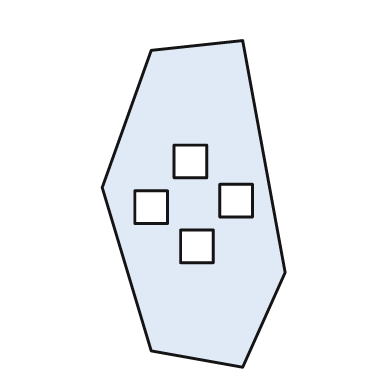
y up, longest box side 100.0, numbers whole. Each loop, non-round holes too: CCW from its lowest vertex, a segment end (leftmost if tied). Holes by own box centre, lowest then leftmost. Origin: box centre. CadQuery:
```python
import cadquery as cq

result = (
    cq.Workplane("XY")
    .moveTo(15.0, -50.0)
    .lineTo(28.0, -21.0)
    .lineTo(15.0, 50.0)
    .lineTo(-13.0, 47.0)
    .lineTo(-28.0, 5.0)
    .lineTo(-13.0, -45.0)
    .close()
    .moveTo(-4.0, -18.0)
    .lineTo(6.0, -18.0)
    .lineTo(6.0, -8.0)
    .lineTo(-4.0, -8.0)
    .close()
    .moveTo(-18.0, -6.0)
    .lineTo(-8.0, -6.0)
    .lineTo(-8.0, 4.0)
    .lineTo(-18.0, 4.0)
    .close()
    .moveTo(8.0, -4.0)
    .lineTo(18.0, -4.0)
    .lineTo(18.0, 6.0)
    .lineTo(8.0, 6.0)
    .close()
    .moveTo(-6.0, 8.0)
    .lineTo(4.0, 8.0)
    .lineTo(4.0, 18.0)
    .lineTo(-6.0, 18.0)
    .close()
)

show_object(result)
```